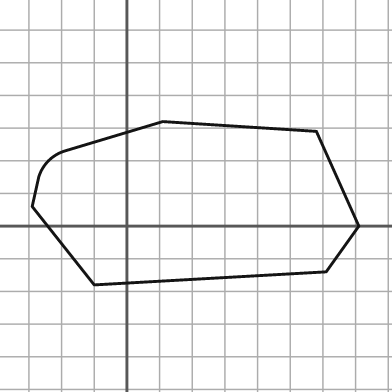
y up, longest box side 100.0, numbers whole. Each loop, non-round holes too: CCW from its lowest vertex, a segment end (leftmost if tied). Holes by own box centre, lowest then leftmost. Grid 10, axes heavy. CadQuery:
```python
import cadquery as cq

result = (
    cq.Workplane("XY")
    .moveTo(-10.0, -18.0)
    .lineTo(61.0, -14.0)
    .lineTo(71.0, 0.0)
    .lineTo(58.0, 29.0)
    .lineTo(11.0, 32.0)
    .lineTo(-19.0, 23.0)
    .threePointArc((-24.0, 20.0), (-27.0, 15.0))
    .lineTo(-29.0, 6.0)
    .close()
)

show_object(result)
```